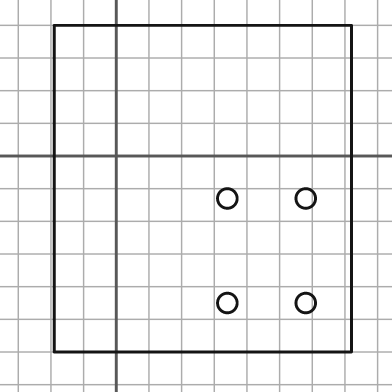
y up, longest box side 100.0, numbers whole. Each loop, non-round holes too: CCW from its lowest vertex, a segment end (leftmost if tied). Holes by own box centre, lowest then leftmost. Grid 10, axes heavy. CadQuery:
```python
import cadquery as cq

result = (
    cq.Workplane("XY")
    .moveTo(-19.0, -60.0)
    .lineTo(72.0, -60.0)
    .lineTo(72.0, 40.0)
    .lineTo(-19.0, 40.0)
    .close()
    .moveTo(34.0, -45.0)
    .circle(3.0)
    .moveTo(58.0, -45.0)
    .circle(3.0)
    .moveTo(34.0, -13.0)
    .circle(3.0)
    .moveTo(58.0, -13.0)
    .circle(3.0)
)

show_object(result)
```